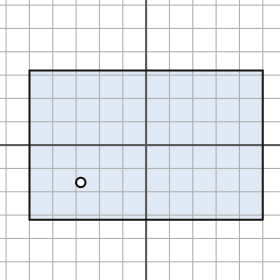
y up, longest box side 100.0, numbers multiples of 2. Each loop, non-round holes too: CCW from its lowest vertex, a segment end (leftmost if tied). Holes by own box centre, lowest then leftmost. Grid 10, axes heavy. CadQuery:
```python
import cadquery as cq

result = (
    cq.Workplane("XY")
    .moveTo(-50.0, -32.0)
    .lineTo(50.0, -32.0)
    .lineTo(50.0, 32.0)
    .lineTo(-50.0, 32.0)
    .close()
    .moveTo(-28.0, -16.0)
    .circle(2.0)
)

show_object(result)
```